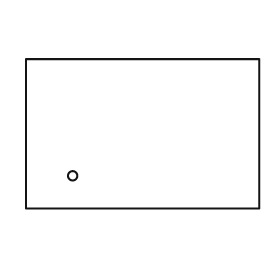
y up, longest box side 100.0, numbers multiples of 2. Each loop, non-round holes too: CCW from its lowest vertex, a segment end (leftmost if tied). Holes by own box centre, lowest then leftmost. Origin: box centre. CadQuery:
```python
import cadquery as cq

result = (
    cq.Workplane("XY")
    .moveTo(-50.0, -32.0)
    .lineTo(50.0, -32.0)
    .lineTo(50.0, 32.0)
    .lineTo(-50.0, 32.0)
    .close()
    .moveTo(-30.0, -18.0)
    .circle(2.0)
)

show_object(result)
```